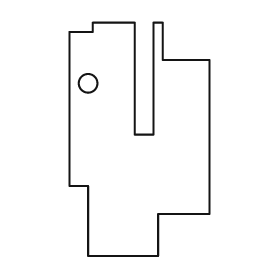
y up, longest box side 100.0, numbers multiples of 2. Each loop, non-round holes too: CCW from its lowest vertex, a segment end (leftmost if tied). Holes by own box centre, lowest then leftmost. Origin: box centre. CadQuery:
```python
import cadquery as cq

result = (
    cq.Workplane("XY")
    .moveTo(-22.0, -50.0)
    .lineTo(8.0, -50.0)
    .lineTo(8.0, -32.0)
    .lineTo(30.0, -32.0)
    .lineTo(30.0, 34.0)
    .lineTo(10.0, 34.0)
    .lineTo(10.0, 50.0)
    .lineTo(6.0, 50.0)
    .lineTo(6.0, 2.0)
    .lineTo(-2.0, 2.0)
    .lineTo(-2.0, 50.0)
    .lineTo(-20.0, 50.0)
    .lineTo(-20.0, 46.0)
    .lineTo(-30.0, 46.0)
    .lineTo(-30.0, -20.0)
    .lineTo(-22.0, -20.0)
    .close()
    .moveTo(-22.0, 24.0)
    .circle(4.0)
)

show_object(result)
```